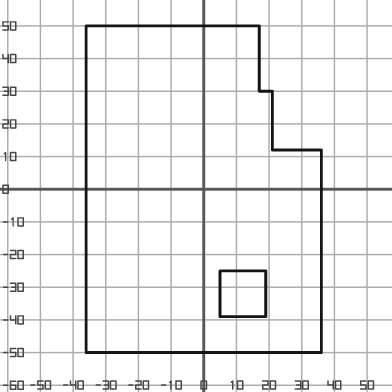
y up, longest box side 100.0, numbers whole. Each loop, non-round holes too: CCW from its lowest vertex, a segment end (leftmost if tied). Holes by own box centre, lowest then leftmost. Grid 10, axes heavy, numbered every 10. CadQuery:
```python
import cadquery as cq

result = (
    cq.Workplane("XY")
    .moveTo(-36.0, -50.0)
    .lineTo(36.0, -50.0)
    .lineTo(36.0, 12.0)
    .lineTo(21.0, 12.0)
    .lineTo(21.0, 30.0)
    .lineTo(17.0, 30.0)
    .lineTo(17.0, 50.0)
    .lineTo(-36.0, 50.0)
    .close()
    .moveTo(5.0, -39.0)
    .lineTo(19.0, -39.0)
    .lineTo(19.0, -25.0)
    .lineTo(5.0, -25.0)
    .close()
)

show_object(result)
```